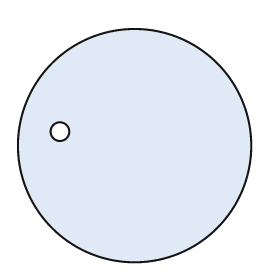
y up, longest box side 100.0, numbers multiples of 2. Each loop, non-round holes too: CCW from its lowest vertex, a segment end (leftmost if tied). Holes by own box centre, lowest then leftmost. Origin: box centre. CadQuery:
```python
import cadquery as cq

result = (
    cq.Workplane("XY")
    .moveTo(0.0, 0.0)
    .circle(50.0)
    .moveTo(-32.0, 6.0)
    .circle(4.0)
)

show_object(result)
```